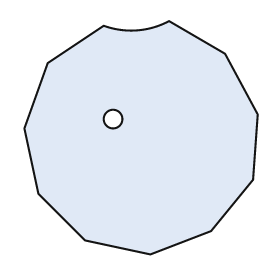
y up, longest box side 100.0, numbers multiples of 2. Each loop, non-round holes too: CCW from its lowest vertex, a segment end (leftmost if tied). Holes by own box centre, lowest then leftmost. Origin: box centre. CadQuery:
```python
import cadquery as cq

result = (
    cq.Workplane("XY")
    .moveTo(4.0, -50.0)
    .lineTo(30.0, -40.0)
    .lineTo(48.0, -18.0)
    .lineTo(50.0, 10.0)
    .lineTo(36.0, 36.0)
    .lineTo(12.0, 50.0)
    .threePointArc((-2.0, 46.0), (-16.0, 48.0))
    .lineTo(-40.0, 32.0)
    .lineTo(-50.0, 4.0)
    .lineTo(-44.0, -24.0)
    .lineTo(-24.0, -44.0)
    .close()
    .moveTo(-12.0, 8.0)
    .circle(4.0)
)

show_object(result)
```